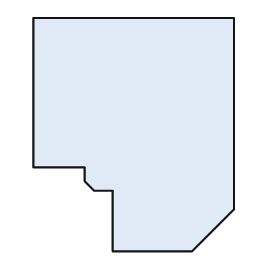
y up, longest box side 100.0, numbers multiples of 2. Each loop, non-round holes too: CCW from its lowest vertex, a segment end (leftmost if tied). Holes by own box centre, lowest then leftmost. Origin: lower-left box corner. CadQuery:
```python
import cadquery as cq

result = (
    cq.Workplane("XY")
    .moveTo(34.0, 0.0)
    .lineTo(68.0, 0.0)
    .lineTo(86.0, 18.0)
    .lineTo(86.0, 100.0)
    .lineTo(0.0, 100.0)
    .lineTo(0.0, 36.0)
    .lineTo(22.0, 36.0)
    .lineTo(22.0, 30.0)
    .lineTo(26.0, 26.0)
    .lineTo(34.0, 26.0)
    .close()
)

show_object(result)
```